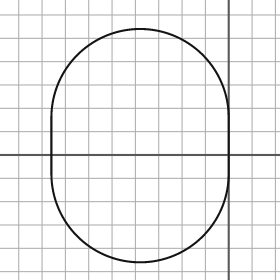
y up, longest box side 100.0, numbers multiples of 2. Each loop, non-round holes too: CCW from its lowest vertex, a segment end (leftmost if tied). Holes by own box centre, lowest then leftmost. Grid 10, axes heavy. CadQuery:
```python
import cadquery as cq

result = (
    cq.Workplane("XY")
    .moveTo(-76.0, -8.0)
    .threePointArc((-38.0, -46.0), (0.0, -8.0))
    .lineTo(0.0, 16.0)
    .threePointArc((-38.0, 54.0), (-76.0, 16.0))
    .close()
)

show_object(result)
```